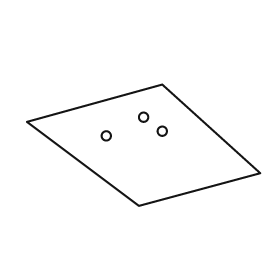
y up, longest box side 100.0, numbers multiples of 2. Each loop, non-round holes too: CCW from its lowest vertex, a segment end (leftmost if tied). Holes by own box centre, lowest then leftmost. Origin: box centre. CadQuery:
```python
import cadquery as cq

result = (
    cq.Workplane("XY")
    .moveTo(-2.0, -26.0)
    .lineTo(50.0, -12.0)
    .lineTo(8.0, 26.0)
    .lineTo(-50.0, 10.0)
    .close()
    .moveTo(-16.0, 4.0)
    .circle(2.0)
    .moveTo(8.0, 6.0)
    .circle(2.0)
    .moveTo(0.0, 12.0)
    .circle(2.0)
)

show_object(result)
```